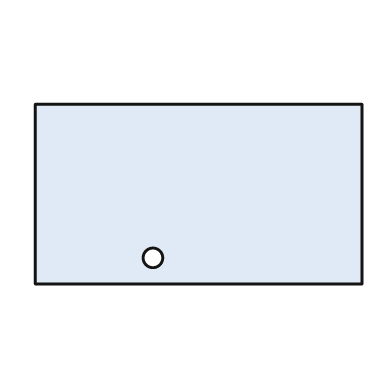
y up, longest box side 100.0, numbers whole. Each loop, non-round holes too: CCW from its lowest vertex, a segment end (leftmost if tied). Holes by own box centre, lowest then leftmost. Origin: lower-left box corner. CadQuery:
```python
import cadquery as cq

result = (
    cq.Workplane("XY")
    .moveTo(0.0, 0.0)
    .lineTo(100.0, 0.0)
    .lineTo(100.0, 55.0)
    .lineTo(0.0, 55.0)
    .close()
    .moveTo(36.0, 8.0)
    .circle(3.0)
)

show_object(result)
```